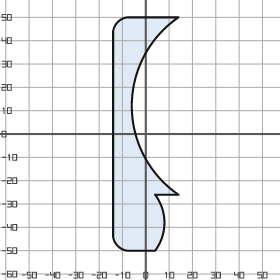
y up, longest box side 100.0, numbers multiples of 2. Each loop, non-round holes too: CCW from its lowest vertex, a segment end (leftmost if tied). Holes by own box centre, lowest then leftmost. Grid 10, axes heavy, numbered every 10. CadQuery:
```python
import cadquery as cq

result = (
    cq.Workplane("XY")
    .moveTo(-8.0, -50.0)
    .lineTo(4.0, -50.0)
    .threePointArc((8.0, -38.0), (4.0, -26.0))
    .lineTo(14.0, -26.0)
    .threePointArc((-6.0, 12.0), (14.0, 50.0))
    .lineTo(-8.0, 50.0)
    .threePointArc((-12.0, 48.0), (-14.0, 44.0))
    .lineTo(-14.0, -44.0)
    .threePointArc((-12.0, -48.0), (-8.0, -50.0))
    .close()
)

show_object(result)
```